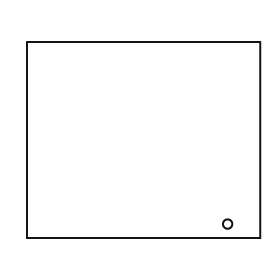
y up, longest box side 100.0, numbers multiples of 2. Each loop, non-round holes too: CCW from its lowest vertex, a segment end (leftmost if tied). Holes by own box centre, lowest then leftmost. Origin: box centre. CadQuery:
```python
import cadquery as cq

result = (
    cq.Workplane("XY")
    .moveTo(-50.0, -42.0)
    .lineTo(50.0, -42.0)
    .lineTo(50.0, 42.0)
    .lineTo(-50.0, 42.0)
    .close()
    .moveTo(36.0, -36.0)
    .circle(2.0)
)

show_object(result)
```